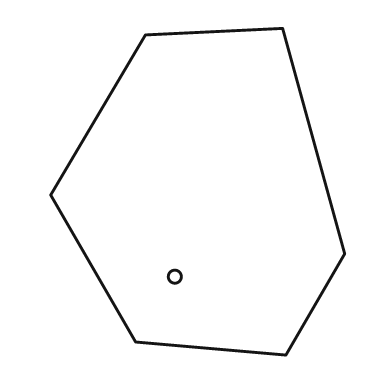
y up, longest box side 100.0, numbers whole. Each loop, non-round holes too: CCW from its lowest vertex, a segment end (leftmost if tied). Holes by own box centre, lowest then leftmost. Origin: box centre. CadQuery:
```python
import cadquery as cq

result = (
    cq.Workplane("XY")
    .moveTo(27.0, -50.0)
    .lineTo(45.0, -19.0)
    .lineTo(26.0, 50.0)
    .lineTo(-16.0, 48.0)
    .lineTo(-45.0, -1.0)
    .lineTo(-19.0, -46.0)
    .close()
    .moveTo(-7.0, -26.0)
    .circle(2.0)
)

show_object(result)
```